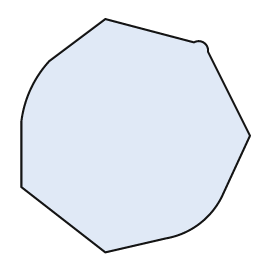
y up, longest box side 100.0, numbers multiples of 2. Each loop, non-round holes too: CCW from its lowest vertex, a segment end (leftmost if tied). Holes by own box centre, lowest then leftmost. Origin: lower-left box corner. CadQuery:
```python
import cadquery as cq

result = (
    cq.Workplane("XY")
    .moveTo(36.0, 0.0)
    .lineTo(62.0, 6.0)
    .threePointArc((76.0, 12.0), (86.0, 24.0))
    .lineTo(98.0, 50.0)
    .lineTo(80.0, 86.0)
    .threePointArc((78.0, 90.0), (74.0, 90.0))
    .lineTo(36.0, 100.0)
    .lineTo(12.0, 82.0)
    .threePointArc((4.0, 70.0), (0.0, 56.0))
    .lineTo(0.0, 28.0)
    .close()
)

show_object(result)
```